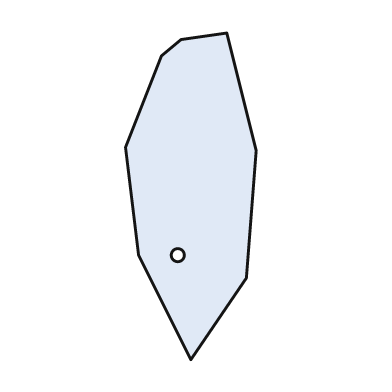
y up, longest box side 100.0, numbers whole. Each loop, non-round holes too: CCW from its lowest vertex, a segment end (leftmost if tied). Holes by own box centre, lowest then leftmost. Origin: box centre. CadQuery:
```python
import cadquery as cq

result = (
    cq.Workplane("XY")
    .moveTo(0.0, -50.0)
    .lineTo(17.0, -25.0)
    .lineTo(20.0, 14.0)
    .lineTo(11.0, 50.0)
    .lineTo(-3.0, 48.0)
    .lineTo(-9.0, 43.0)
    .lineTo(-20.0, 15.0)
    .lineTo(-16.0, -18.0)
    .close()
    .moveTo(-4.0, -18.0)
    .circle(2.0)
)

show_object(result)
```